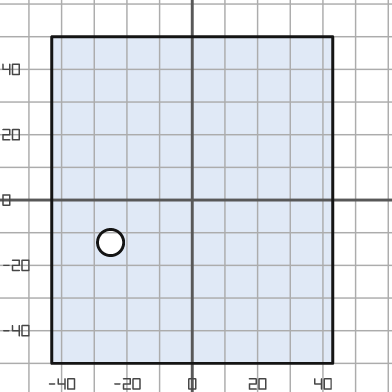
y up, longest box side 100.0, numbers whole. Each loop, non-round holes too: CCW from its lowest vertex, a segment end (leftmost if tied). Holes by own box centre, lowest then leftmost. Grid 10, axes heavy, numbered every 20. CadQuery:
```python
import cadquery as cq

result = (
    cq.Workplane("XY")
    .moveTo(-43.0, -50.0)
    .lineTo(43.0, -50.0)
    .lineTo(43.0, 50.0)
    .lineTo(-43.0, 50.0)
    .close()
    .moveTo(-25.0, -13.0)
    .circle(4.0)
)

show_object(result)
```